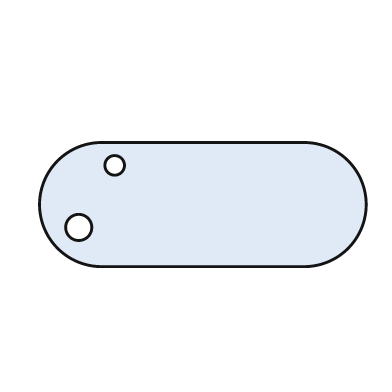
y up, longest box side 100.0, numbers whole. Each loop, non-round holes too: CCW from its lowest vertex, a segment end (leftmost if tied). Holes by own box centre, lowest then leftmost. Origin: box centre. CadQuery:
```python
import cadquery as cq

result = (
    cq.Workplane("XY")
    .moveTo(-31.0, -19.0)
    .lineTo(31.0, -19.0)
    .threePointArc((50.0, 0.0), (31.0, 19.0))
    .lineTo(-31.0, 19.0)
    .threePointArc((-50.0, 0.0), (-31.0, -19.0))
    .close()
    .moveTo(-38.0, -7.0)
    .circle(4.0)
    .moveTo(-27.0, 12.0)
    .circle(3.0)
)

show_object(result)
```